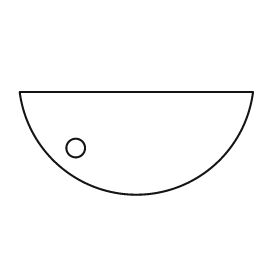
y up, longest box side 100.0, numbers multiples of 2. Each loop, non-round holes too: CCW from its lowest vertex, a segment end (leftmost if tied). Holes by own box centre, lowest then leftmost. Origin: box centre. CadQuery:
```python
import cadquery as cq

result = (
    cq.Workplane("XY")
    .moveTo(-50.0, 22.0)
    .threePointArc((0.0, -22.0), (50.0, 22.0))
    .close()
    .moveTo(-26.0, -2.0)
    .circle(4.0)
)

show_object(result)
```